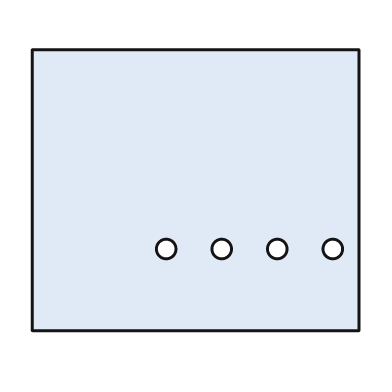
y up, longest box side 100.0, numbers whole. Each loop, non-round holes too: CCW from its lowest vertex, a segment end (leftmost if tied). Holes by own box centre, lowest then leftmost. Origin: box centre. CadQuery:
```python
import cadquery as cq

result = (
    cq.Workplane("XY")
    .moveTo(-50.0, -43.0)
    .lineTo(50.0, -43.0)
    .lineTo(50.0, 43.0)
    .lineTo(-50.0, 43.0)
    .close()
    .moveTo(-9.0, -18.0)
    .circle(3.0)
    .moveTo(8.0, -18.0)
    .circle(3.0)
    .moveTo(25.0, -18.0)
    .circle(3.0)
    .moveTo(42.0, -18.0)
    .circle(3.0)
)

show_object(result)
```